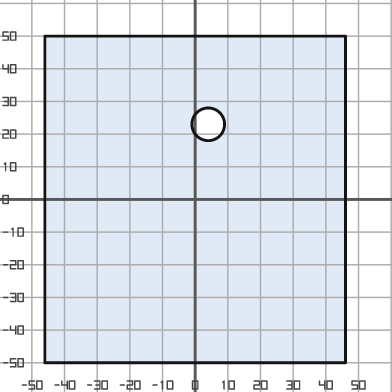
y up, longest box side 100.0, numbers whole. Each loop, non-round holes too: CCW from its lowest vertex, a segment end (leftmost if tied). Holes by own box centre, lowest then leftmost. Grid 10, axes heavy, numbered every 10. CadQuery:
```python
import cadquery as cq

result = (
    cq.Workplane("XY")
    .moveTo(-46.0, -50.0)
    .lineTo(46.0, -50.0)
    .lineTo(46.0, 50.0)
    .lineTo(-46.0, 50.0)
    .close()
    .moveTo(4.0, 23.0)
    .circle(5.0)
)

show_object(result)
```